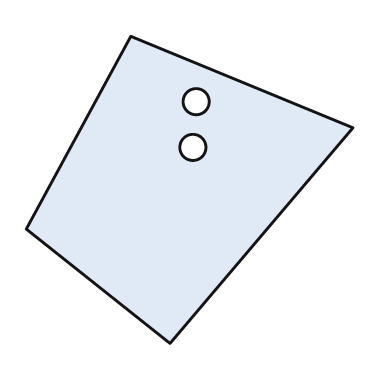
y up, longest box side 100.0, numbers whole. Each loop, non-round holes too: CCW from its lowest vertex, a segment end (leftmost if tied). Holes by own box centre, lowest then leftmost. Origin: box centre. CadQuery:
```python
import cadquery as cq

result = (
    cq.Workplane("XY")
    .moveTo(-6.0, -47.0)
    .lineTo(50.0, 19.0)
    .lineTo(-18.0, 47.0)
    .lineTo(-50.0, -12.0)
    .close()
    .moveTo(1.0, 13.0)
    .circle(4.0)
    .moveTo(2.0, 27.0)
    .circle(4.0)
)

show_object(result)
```